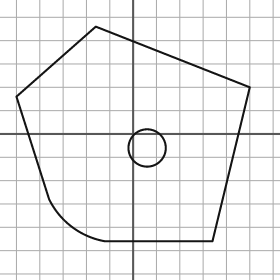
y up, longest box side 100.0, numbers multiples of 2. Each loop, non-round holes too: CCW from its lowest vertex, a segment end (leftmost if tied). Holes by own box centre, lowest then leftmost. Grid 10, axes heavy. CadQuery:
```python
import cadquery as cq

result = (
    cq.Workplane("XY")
    .moveTo(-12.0, -46.0)
    .lineTo(34.0, -46.0)
    .lineTo(50.0, 20.0)
    .lineTo(-16.0, 46.0)
    .lineTo(-50.0, 16.0)
    .lineTo(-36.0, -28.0)
    .threePointArc((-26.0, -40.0), (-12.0, -46.0))
    .close()
    .moveTo(6.0, -6.0)
    .circle(8.0)
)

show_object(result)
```